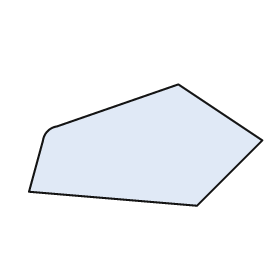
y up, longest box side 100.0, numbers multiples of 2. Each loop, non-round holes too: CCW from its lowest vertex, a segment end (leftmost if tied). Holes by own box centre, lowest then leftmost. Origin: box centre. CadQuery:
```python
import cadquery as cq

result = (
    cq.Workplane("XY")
    .moveTo(22.0, -26.0)
    .lineTo(50.0, 2.0)
    .lineTo(14.0, 26.0)
    .lineTo(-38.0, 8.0)
    .threePointArc((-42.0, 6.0), (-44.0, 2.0))
    .lineTo(-50.0, -20.0)
    .close()
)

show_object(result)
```